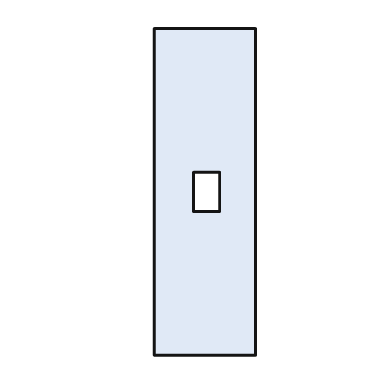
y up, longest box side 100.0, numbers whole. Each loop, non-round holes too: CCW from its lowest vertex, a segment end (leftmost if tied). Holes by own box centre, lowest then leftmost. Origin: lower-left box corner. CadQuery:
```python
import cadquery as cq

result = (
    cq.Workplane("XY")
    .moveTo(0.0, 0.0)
    .lineTo(31.0, 0.0)
    .lineTo(31.0, 100.0)
    .lineTo(0.0, 100.0)
    .close()
    .moveTo(12.0, 44.0)
    .lineTo(20.0, 44.0)
    .lineTo(20.0, 56.0)
    .lineTo(12.0, 56.0)
    .close()
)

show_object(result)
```